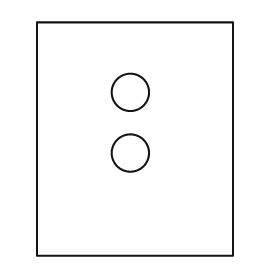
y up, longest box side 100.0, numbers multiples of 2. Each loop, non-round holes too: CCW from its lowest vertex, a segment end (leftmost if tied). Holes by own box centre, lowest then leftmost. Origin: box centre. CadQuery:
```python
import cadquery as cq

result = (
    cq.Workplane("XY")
    .moveTo(-42.0, -50.0)
    .lineTo(42.0, -50.0)
    .lineTo(42.0, 50.0)
    .lineTo(-42.0, 50.0)
    .close()
    .moveTo(-2.0, -6.0)
    .circle(8.0)
    .moveTo(-2.0, 20.0)
    .circle(8.0)
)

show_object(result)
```